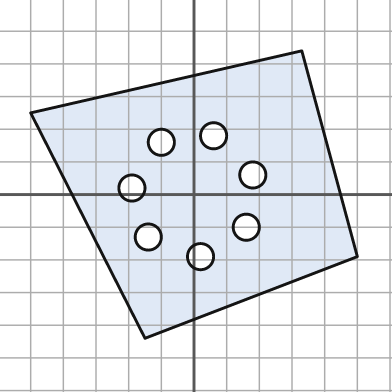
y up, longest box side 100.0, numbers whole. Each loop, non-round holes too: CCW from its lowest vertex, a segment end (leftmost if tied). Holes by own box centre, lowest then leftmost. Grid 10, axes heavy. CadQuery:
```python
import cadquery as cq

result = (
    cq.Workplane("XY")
    .moveTo(-15.0, -44.0)
    .lineTo(50.0, -19.0)
    .lineTo(33.0, 44.0)
    .lineTo(-50.0, 25.0)
    .close()
    .moveTo(2.0, -19.0)
    .circle(4.0)
    .moveTo(-14.0, -13.0)
    .circle(4.0)
    .moveTo(16.0, -10.0)
    .circle(4.0)
    .moveTo(-19.0, 2.0)
    .circle(4.0)
    .moveTo(18.0, 6.0)
    .circle(4.0)
    .moveTo(-10.0, 16.0)
    .circle(4.0)
    .moveTo(6.0, 18.0)
    .circle(4.0)
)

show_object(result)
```